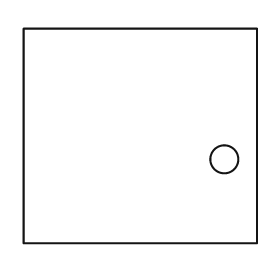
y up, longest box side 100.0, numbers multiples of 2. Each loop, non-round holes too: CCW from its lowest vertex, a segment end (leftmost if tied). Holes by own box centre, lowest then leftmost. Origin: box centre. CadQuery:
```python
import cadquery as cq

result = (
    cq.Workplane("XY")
    .moveTo(-50.0, -46.0)
    .lineTo(50.0, -46.0)
    .lineTo(50.0, 46.0)
    .lineTo(-50.0, 46.0)
    .close()
    .moveTo(36.0, -10.0)
    .circle(6.0)
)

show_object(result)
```